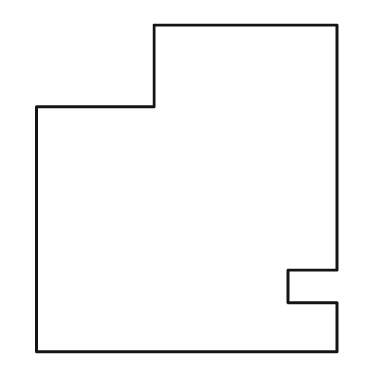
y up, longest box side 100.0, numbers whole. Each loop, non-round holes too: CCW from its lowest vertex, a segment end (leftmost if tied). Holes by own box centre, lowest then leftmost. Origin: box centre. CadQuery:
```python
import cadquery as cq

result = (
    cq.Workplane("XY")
    .moveTo(-46.0, -50.0)
    .lineTo(46.0, -50.0)
    .lineTo(46.0, -35.0)
    .lineTo(31.0, -35.0)
    .lineTo(31.0, -25.0)
    .lineTo(46.0, -25.0)
    .lineTo(46.0, 50.0)
    .lineTo(-10.0, 50.0)
    .lineTo(-10.0, 25.0)
    .lineTo(-46.0, 25.0)
    .close()
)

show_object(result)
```